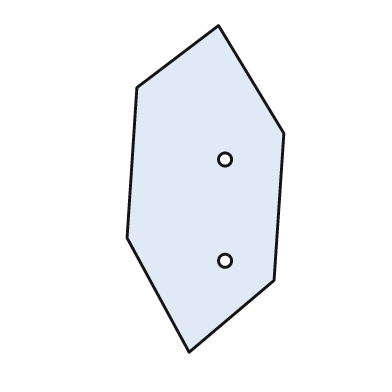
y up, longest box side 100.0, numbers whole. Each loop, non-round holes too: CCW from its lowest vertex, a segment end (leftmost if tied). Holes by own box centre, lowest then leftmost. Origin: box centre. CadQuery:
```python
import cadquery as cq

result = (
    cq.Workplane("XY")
    .moveTo(-5.0, -50.0)
    .lineTo(21.0, -28.0)
    .lineTo(24.0, 17.0)
    .lineTo(4.0, 50.0)
    .lineTo(-21.0, 31.0)
    .lineTo(-24.0, -15.0)
    .close()
    .moveTo(6.0, -22.0)
    .circle(2.0)
    .moveTo(6.0, 9.0)
    .circle(2.0)
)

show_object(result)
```